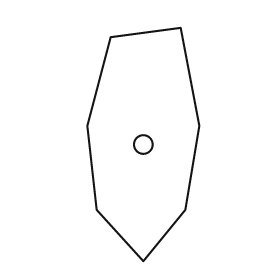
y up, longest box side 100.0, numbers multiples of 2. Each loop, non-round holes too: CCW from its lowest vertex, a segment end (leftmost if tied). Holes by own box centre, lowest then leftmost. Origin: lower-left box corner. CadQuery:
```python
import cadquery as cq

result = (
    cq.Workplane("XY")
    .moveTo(24.0, 0.0)
    .lineTo(42.0, 22.0)
    .lineTo(48.0, 58.0)
    .lineTo(40.0, 100.0)
    .lineTo(10.0, 96.0)
    .lineTo(0.0, 58.0)
    .lineTo(4.0, 22.0)
    .close()
    .moveTo(24.0, 50.0)
    .circle(4.0)
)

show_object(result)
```